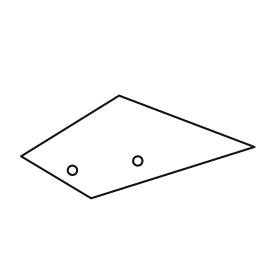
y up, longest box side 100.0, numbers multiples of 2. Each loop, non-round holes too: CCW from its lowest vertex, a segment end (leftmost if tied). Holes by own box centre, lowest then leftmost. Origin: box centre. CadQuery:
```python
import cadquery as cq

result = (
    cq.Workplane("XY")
    .moveTo(-20.0, -22.0)
    .lineTo(50.0, 0.0)
    .lineTo(-8.0, 22.0)
    .lineTo(-50.0, -4.0)
    .close()
    .moveTo(-28.0, -10.0)
    .circle(2.0)
    .moveTo(0.0, -6.0)
    .circle(2.0)
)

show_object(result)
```